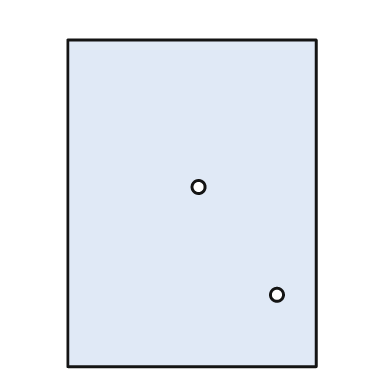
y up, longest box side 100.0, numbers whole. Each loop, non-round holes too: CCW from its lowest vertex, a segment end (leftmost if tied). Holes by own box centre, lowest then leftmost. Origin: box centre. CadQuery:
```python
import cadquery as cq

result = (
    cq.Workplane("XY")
    .moveTo(-38.0, -50.0)
    .lineTo(38.0, -50.0)
    .lineTo(38.0, 50.0)
    .lineTo(-38.0, 50.0)
    .close()
    .moveTo(26.0, -28.0)
    .circle(2.0)
    .moveTo(2.0, 5.0)
    .circle(2.0)
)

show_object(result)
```